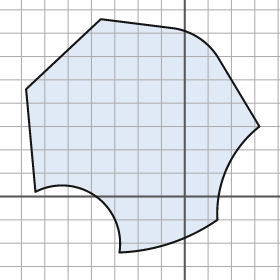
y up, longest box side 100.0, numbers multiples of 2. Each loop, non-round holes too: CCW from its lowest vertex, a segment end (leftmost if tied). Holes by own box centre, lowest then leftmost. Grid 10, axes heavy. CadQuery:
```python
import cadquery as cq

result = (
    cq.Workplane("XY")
    .moveTo(-28.0, -24.0)
    .threePointArc((-6.0, -20.0), (14.0, -10.0))
    .threePointArc((18.0, 12.0), (32.0, 30.0))
    .lineTo(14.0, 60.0)
    .threePointArc((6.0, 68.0), (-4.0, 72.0))
    .lineTo(-36.0, 76.0)
    .lineTo(-68.0, 46.0)
    .lineTo(-64.0, 2.0)
    .threePointArc((-38.0, 0.0), (-28.0, -24.0))
    .close()
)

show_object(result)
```